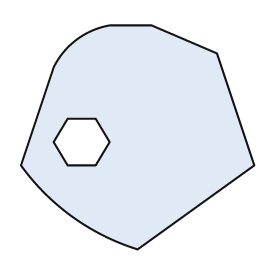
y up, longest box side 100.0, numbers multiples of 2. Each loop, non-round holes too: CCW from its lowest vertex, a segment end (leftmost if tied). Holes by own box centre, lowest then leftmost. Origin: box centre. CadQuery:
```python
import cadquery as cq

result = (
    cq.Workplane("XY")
    .moveTo(0.0, -48.0)
    .lineTo(50.0, -12.0)
    .lineTo(34.0, 36.0)
    .lineTo(6.0, 48.0)
    .lineTo(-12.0, 48.0)
    .threePointArc((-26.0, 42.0), (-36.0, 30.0))
    .lineTo(-50.0, -12.0)
    .threePointArc((-28.0, -34.0), (0.0, -48.0))
    .close()
    .moveTo(-30.0, -12.0)
    .lineTo(-18.0, -12.0)
    .lineTo(-12.0, -2.0)
    .lineTo(-18.0, 8.0)
    .lineTo(-30.0, 8.0)
    .lineTo(-36.0, -2.0)
    .close()
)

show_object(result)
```